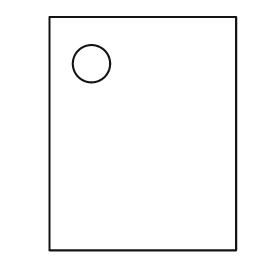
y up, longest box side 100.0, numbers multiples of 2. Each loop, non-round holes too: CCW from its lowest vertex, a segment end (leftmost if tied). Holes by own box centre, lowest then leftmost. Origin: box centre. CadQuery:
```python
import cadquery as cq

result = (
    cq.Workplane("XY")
    .moveTo(-40.0, -50.0)
    .lineTo(40.0, -50.0)
    .lineTo(40.0, 50.0)
    .lineTo(-40.0, 50.0)
    .close()
    .moveTo(-22.0, 30.0)
    .circle(8.0)
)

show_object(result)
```